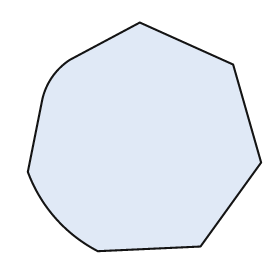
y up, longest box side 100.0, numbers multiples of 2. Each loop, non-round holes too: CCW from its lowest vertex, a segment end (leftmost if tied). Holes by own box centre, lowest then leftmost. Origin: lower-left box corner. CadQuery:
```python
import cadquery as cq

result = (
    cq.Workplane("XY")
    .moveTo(30.0, 0.0)
    .lineTo(74.0, 2.0)
    .lineTo(100.0, 38.0)
    .lineTo(88.0, 80.0)
    .lineTo(48.0, 98.0)
    .lineTo(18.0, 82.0)
    .threePointArc((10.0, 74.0), (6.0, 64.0))
    .lineTo(0.0, 34.0)
    .threePointArc((12.0, 14.0), (30.0, 0.0))
    .close()
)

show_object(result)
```